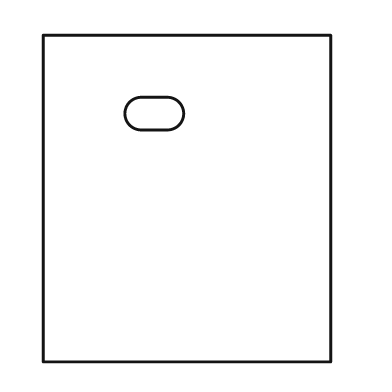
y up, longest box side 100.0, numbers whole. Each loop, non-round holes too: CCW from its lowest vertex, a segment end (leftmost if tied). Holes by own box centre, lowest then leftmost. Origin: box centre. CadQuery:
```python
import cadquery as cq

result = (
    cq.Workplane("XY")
    .moveTo(-44.0, -50.0)
    .lineTo(44.0, -50.0)
    .lineTo(44.0, 50.0)
    .lineTo(-44.0, 50.0)
    .close()
    .moveTo(-14.0, 21.0)
    .lineTo(-6.0, 21.0)
    .threePointArc((-1.0, 26.0), (-6.0, 31.0))
    .lineTo(-14.0, 31.0)
    .threePointArc((-19.0, 26.0), (-14.0, 21.0))
    .close()
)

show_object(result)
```